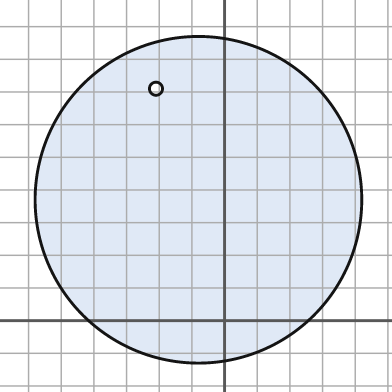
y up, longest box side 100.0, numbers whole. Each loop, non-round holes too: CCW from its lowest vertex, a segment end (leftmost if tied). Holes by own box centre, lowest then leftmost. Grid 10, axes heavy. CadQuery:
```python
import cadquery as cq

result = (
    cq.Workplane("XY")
    .moveTo(-8.0, 37.0)
    .circle(50.0)
    .moveTo(-21.0, 71.0)
    .circle(2.0)
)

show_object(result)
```